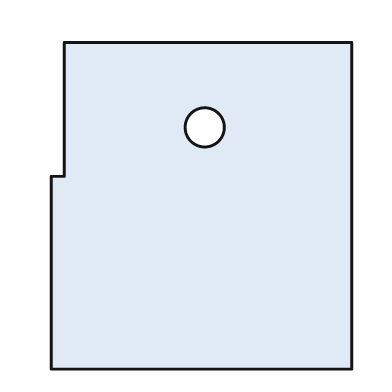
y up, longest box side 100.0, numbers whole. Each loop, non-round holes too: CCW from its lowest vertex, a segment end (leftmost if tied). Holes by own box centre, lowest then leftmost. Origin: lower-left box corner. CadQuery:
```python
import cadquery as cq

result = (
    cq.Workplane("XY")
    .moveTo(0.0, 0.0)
    .lineTo(92.0, 0.0)
    .lineTo(92.0, 100.0)
    .lineTo(4.0, 100.0)
    .lineTo(4.0, 59.0)
    .lineTo(0.0, 59.0)
    .close()
    .moveTo(47.0, 74.0)
    .circle(6.0)
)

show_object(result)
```